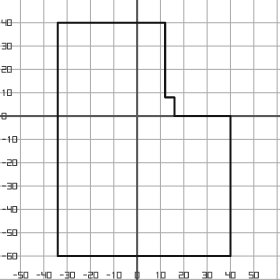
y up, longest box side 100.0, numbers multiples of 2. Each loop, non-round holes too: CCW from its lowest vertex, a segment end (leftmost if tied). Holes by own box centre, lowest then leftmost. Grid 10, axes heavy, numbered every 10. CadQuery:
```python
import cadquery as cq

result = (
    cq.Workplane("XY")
    .moveTo(-34.0, -60.0)
    .lineTo(40.0, -60.0)
    .lineTo(40.0, 0.0)
    .lineTo(16.0, 0.0)
    .lineTo(16.0, 8.0)
    .lineTo(12.0, 8.0)
    .lineTo(12.0, 40.0)
    .lineTo(-34.0, 40.0)
    .close()
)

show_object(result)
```